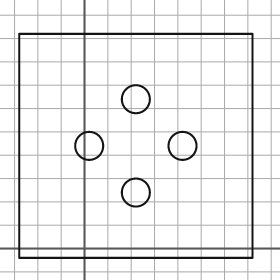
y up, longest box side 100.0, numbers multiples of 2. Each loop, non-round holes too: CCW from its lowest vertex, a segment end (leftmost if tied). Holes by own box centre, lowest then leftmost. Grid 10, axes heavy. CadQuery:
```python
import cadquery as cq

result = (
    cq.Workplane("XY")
    .moveTo(-28.0, -4.0)
    .lineTo(72.0, -4.0)
    .lineTo(72.0, 92.0)
    .lineTo(-28.0, 92.0)
    .close()
    .moveTo(22.0, 24.0)
    .circle(6.0)
    .moveTo(2.0, 44.0)
    .circle(6.0)
    .moveTo(42.0, 44.0)
    .circle(6.0)
    .moveTo(22.0, 64.0)
    .circle(6.0)
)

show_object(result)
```